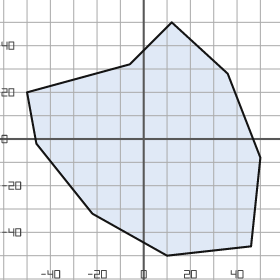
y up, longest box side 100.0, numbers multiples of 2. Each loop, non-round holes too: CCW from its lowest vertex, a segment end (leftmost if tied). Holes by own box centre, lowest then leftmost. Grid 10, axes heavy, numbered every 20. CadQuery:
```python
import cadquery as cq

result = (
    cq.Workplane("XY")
    .moveTo(10.0, -50.0)
    .lineTo(46.0, -46.0)
    .lineTo(50.0, -8.0)
    .lineTo(36.0, 28.0)
    .lineTo(12.0, 50.0)
    .lineTo(-6.0, 32.0)
    .lineTo(-50.0, 20.0)
    .lineTo(-46.0, -2.0)
    .lineTo(-22.0, -32.0)
    .close()
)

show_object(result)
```